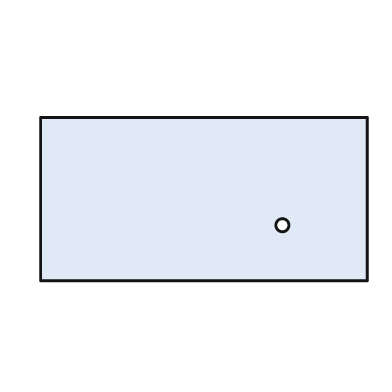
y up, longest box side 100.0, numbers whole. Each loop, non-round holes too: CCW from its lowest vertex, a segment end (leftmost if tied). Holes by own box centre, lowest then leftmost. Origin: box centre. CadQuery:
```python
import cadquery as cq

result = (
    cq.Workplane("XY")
    .moveTo(-50.0, -25.0)
    .lineTo(50.0, -25.0)
    .lineTo(50.0, 25.0)
    .lineTo(-50.0, 25.0)
    .close()
    .moveTo(24.0, -8.0)
    .circle(2.0)
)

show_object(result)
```